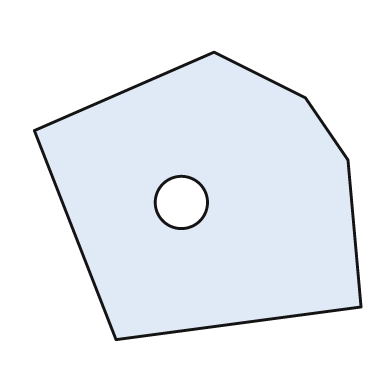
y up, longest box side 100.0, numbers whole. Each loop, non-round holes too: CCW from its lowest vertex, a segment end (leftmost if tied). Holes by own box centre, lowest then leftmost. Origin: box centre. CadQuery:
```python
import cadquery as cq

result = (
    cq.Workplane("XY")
    .moveTo(-25.0, -44.0)
    .lineTo(50.0, -34.0)
    .lineTo(46.0, 11.0)
    .lineTo(33.0, 30.0)
    .lineTo(5.0, 44.0)
    .lineTo(-50.0, 20.0)
    .close()
    .moveTo(-5.0, -2.0)
    .circle(8.0)
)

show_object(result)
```